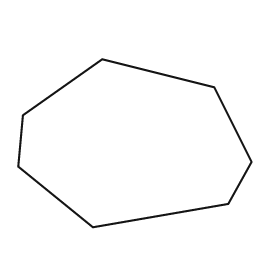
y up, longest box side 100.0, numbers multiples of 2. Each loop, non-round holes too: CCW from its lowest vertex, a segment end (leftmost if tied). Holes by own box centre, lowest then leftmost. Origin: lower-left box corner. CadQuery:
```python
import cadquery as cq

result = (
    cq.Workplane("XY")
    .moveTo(32.0, 0.0)
    .lineTo(90.0, 10.0)
    .lineTo(100.0, 28.0)
    .lineTo(84.0, 60.0)
    .lineTo(36.0, 72.0)
    .lineTo(2.0, 48.0)
    .lineTo(0.0, 26.0)
    .close()
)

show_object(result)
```